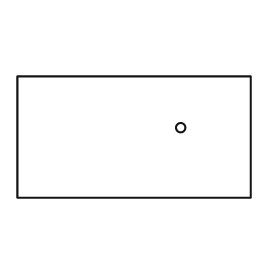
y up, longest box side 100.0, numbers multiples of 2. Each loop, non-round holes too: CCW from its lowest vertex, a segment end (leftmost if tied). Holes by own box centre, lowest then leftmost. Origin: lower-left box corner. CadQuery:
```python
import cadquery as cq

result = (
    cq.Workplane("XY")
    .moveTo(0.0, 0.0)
    .lineTo(100.0, 0.0)
    .lineTo(100.0, 52.0)
    .lineTo(0.0, 52.0)
    .close()
    .moveTo(70.0, 30.0)
    .circle(2.0)
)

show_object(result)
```